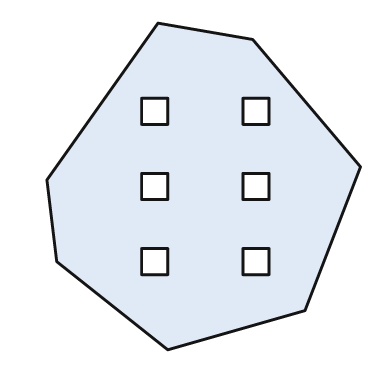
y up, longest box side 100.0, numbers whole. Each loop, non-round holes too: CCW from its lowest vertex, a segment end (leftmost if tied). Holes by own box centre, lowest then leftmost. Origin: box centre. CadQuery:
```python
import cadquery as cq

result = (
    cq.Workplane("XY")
    .moveTo(-11.0, -50.0)
    .lineTo(31.0, -38.0)
    .lineTo(48.0, 6.0)
    .lineTo(15.0, 45.0)
    .lineTo(-14.0, 50.0)
    .lineTo(-48.0, 2.0)
    .lineTo(-45.0, -23.0)
    .close()
    .moveTo(-19.0, -27.0)
    .lineTo(-11.0, -27.0)
    .lineTo(-11.0, -19.0)
    .lineTo(-19.0, -19.0)
    .close()
    .moveTo(12.0, -27.0)
    .lineTo(20.0, -27.0)
    .lineTo(20.0, -19.0)
    .lineTo(12.0, -19.0)
    .close()
    .moveTo(-19.0, -4.0)
    .lineTo(-11.0, -4.0)
    .lineTo(-11.0, 4.0)
    .lineTo(-19.0, 4.0)
    .close()
    .moveTo(12.0, -4.0)
    .lineTo(20.0, -4.0)
    .lineTo(20.0, 4.0)
    .lineTo(12.0, 4.0)
    .close()
    .moveTo(-19.0, 19.0)
    .lineTo(-11.0, 19.0)
    .lineTo(-11.0, 27.0)
    .lineTo(-19.0, 27.0)
    .close()
    .moveTo(12.0, 19.0)
    .lineTo(20.0, 19.0)
    .lineTo(20.0, 27.0)
    .lineTo(12.0, 27.0)
    .close()
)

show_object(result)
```